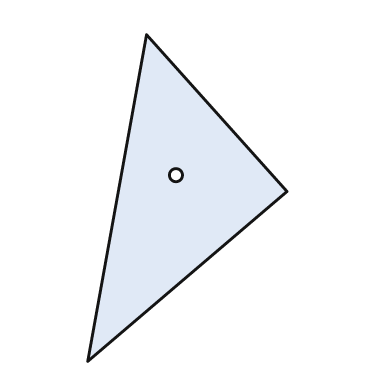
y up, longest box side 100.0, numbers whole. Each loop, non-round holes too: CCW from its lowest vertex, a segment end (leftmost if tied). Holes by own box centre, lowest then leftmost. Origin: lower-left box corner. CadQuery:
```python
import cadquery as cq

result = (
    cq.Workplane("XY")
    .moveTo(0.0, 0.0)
    .lineTo(61.0, 52.0)
    .lineTo(18.0, 100.0)
    .close()
    .moveTo(27.0, 57.0)
    .circle(2.0)
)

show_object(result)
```